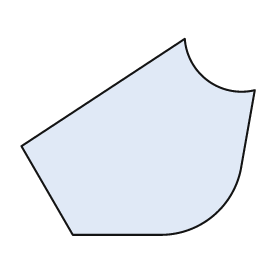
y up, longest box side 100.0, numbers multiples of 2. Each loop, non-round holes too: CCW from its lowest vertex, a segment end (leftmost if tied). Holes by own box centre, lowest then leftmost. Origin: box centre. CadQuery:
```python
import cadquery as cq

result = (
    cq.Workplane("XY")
    .moveTo(-28.0, -42.0)
    .lineTo(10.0, -42.0)
    .threePointArc((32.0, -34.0), (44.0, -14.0))
    .lineTo(50.0, 20.0)
    .threePointArc((30.0, 24.0), (20.0, 42.0))
    .lineTo(-50.0, -4.0)
    .close()
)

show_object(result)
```